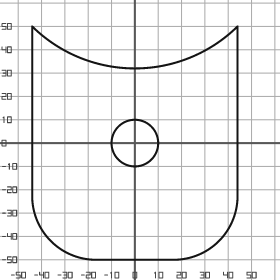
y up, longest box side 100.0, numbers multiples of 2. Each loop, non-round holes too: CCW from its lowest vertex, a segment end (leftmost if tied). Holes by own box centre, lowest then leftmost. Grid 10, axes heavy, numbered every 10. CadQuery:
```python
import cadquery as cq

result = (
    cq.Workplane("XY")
    .moveTo(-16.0, -50.0)
    .lineTo(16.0, -50.0)
    .threePointArc((36.0, -42.0), (44.0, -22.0))
    .lineTo(44.0, 50.0)
    .threePointArc((0.0, 32.0), (-44.0, 50.0))
    .lineTo(-44.0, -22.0)
    .threePointArc((-36.0, -42.0), (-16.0, -50.0))
    .close()
    .moveTo(0.0, 0.0)
    .circle(10.0)
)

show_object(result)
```